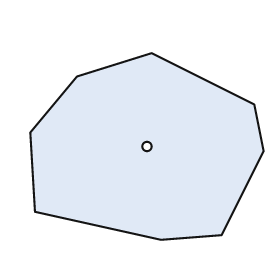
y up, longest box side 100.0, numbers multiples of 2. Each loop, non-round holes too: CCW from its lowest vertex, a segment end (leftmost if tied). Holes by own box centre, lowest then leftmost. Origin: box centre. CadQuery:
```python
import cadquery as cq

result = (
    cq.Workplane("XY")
    .moveTo(6.0, -40.0)
    .lineTo(32.0, -38.0)
    .lineTo(50.0, -2.0)
    .lineTo(46.0, 18.0)
    .lineTo(2.0, 40.0)
    .lineTo(-30.0, 30.0)
    .lineTo(-50.0, 6.0)
    .lineTo(-48.0, -28.0)
    .close()
    .moveTo(0.0, 0.0)
    .circle(2.0)
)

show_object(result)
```